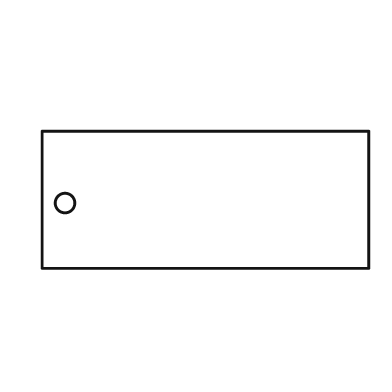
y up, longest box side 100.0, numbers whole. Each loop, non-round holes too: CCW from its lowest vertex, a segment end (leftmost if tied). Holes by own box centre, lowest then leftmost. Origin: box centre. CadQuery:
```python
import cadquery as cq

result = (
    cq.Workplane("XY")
    .moveTo(-50.0, -21.0)
    .lineTo(50.0, -21.0)
    .lineTo(50.0, 21.0)
    .lineTo(-50.0, 21.0)
    .close()
    .moveTo(-43.0, -1.0)
    .circle(3.0)
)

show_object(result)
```